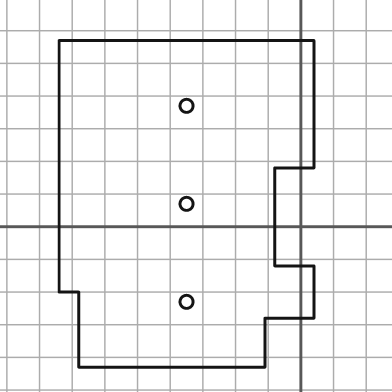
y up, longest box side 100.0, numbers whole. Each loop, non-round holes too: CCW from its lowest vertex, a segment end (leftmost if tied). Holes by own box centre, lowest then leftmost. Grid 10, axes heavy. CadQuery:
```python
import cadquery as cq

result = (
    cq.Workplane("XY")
    .moveTo(-68.0, -43.0)
    .lineTo(-11.0, -43.0)
    .lineTo(-11.0, -28.0)
    .lineTo(4.0, -28.0)
    .lineTo(4.0, -12.0)
    .lineTo(-8.0, -12.0)
    .lineTo(-8.0, 18.0)
    .lineTo(4.0, 18.0)
    .lineTo(4.0, 57.0)
    .lineTo(-74.0, 57.0)
    .lineTo(-74.0, -20.0)
    .lineTo(-68.0, -20.0)
    .close()
    .moveTo(-35.0, -23.0)
    .circle(2.0)
    .moveTo(-35.0, 7.0)
    .circle(2.0)
    .moveTo(-35.0, 37.0)
    .circle(2.0)
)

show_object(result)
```